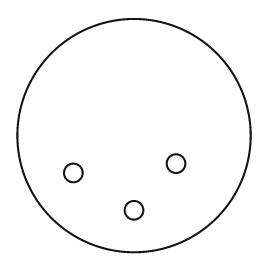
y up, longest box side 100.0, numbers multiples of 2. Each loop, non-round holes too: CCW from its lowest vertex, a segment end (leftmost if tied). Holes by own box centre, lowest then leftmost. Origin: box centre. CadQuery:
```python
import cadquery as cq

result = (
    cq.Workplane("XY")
    .moveTo(0.0, 0.0)
    .circle(50.0)
    .moveTo(0.0, -32.0)
    .circle(4.0)
    .moveTo(-26.0, -16.0)
    .circle(4.0)
    .moveTo(18.0, -12.0)
    .circle(4.0)
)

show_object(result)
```